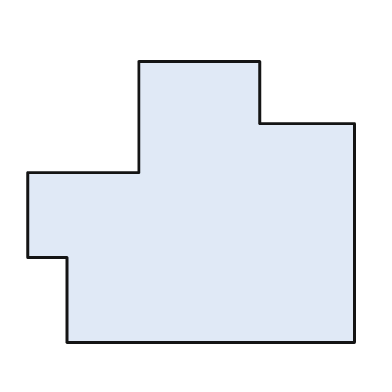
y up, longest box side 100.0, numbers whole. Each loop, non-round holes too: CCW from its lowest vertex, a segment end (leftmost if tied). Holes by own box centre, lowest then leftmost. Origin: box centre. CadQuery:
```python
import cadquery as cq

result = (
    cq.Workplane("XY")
    .moveTo(-38.0, -43.0)
    .lineTo(50.0, -43.0)
    .lineTo(50.0, 24.0)
    .lineTo(21.0, 24.0)
    .lineTo(21.0, 43.0)
    .lineTo(-16.0, 43.0)
    .lineTo(-16.0, 9.0)
    .lineTo(-50.0, 9.0)
    .lineTo(-50.0, -17.0)
    .lineTo(-38.0, -17.0)
    .close()
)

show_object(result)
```